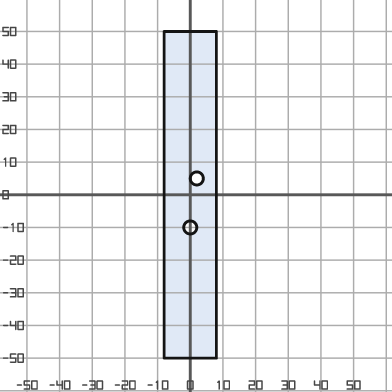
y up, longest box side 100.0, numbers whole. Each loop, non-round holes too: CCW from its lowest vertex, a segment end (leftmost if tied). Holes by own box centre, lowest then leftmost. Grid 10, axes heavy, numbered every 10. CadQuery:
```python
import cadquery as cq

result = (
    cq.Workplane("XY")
    .moveTo(-8.0, -50.0)
    .lineTo(8.0, -50.0)
    .lineTo(8.0, 50.0)
    .lineTo(-8.0, 50.0)
    .close()
    .moveTo(0.0, -10.0)
    .circle(2.0)
    .moveTo(2.0, 5.0)
    .circle(2.0)
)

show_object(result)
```